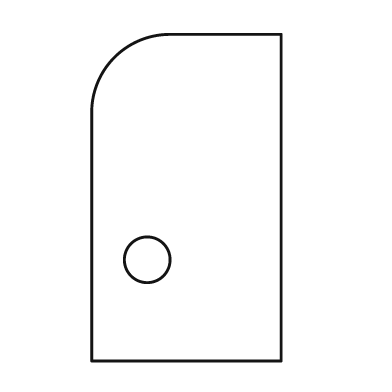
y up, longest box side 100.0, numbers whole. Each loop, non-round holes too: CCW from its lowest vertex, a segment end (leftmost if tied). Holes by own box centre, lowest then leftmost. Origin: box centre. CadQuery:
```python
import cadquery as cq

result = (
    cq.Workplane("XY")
    .moveTo(-29.0, -50.0)
    .lineTo(29.0, -50.0)
    .lineTo(29.0, 50.0)
    .lineTo(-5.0, 50.0)
    .threePointArc((-22.0, 43.0), (-29.0, 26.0))
    .close()
    .moveTo(-12.0, -19.0)
    .circle(7.0)
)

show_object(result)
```